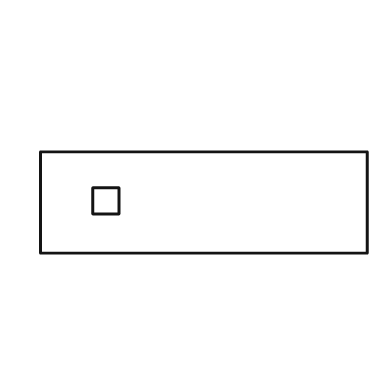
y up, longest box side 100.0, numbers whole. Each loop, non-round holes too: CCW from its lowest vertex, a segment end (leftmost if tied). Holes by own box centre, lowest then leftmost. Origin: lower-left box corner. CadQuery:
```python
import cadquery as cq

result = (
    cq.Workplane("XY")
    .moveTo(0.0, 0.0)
    .lineTo(100.0, 0.0)
    .lineTo(100.0, 31.0)
    .lineTo(0.0, 31.0)
    .close()
    .moveTo(16.0, 12.0)
    .lineTo(24.0, 12.0)
    .lineTo(24.0, 20.0)
    .lineTo(16.0, 20.0)
    .close()
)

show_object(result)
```